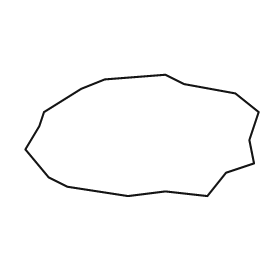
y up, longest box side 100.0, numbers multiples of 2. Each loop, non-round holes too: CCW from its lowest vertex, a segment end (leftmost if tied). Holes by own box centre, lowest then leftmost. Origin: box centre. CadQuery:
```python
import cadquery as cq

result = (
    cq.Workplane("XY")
    .moveTo(-6.0, -26.0)
    .lineTo(10.0, -24.0)
    .lineTo(28.0, -26.0)
    .lineTo(36.0, -16.0)
    .lineTo(48.0, -12.0)
    .lineTo(46.0, -2.0)
    .lineTo(50.0, 10.0)
    .lineTo(40.0, 18.0)
    .lineTo(18.0, 22.0)
    .lineTo(10.0, 26.0)
    .lineTo(-16.0, 24.0)
    .lineTo(-26.0, 20.0)
    .lineTo(-42.0, 10.0)
    .lineTo(-44.0, 4.0)
    .lineTo(-50.0, -6.0)
    .lineTo(-40.0, -18.0)
    .lineTo(-32.0, -22.0)
    .close()
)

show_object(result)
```